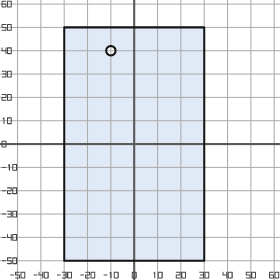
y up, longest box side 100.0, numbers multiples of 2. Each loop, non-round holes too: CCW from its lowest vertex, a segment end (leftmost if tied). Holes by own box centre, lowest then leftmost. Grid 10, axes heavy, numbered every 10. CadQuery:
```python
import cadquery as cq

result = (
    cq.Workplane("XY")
    .moveTo(-30.0, -50.0)
    .lineTo(30.0, -50.0)
    .lineTo(30.0, 50.0)
    .lineTo(-30.0, 50.0)
    .close()
    .moveTo(-10.0, 40.0)
    .circle(2.0)
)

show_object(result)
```